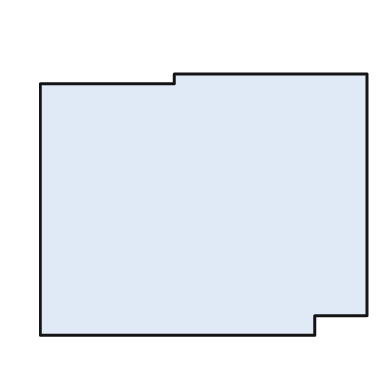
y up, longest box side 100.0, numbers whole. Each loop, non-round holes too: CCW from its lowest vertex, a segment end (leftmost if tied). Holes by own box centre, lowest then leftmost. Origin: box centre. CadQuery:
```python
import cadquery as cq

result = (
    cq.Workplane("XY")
    .moveTo(-50.0, -40.0)
    .lineTo(34.0, -40.0)
    .lineTo(34.0, -34.0)
    .lineTo(50.0, -34.0)
    .lineTo(50.0, 40.0)
    .lineTo(-9.0, 40.0)
    .lineTo(-9.0, 37.0)
    .lineTo(-50.0, 37.0)
    .close()
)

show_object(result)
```